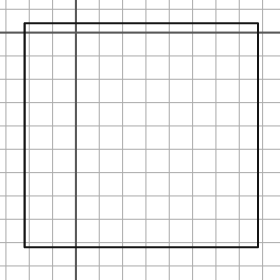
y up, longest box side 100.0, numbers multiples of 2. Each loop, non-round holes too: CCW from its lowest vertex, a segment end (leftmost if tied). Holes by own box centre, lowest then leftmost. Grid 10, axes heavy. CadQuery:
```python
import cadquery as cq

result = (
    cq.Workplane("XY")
    .moveTo(-22.0, -92.0)
    .lineTo(78.0, -92.0)
    .lineTo(78.0, 4.0)
    .lineTo(-22.0, 4.0)
    .close()
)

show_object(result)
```